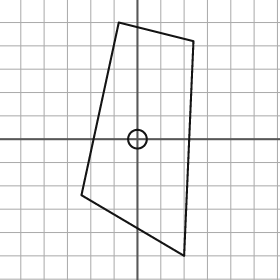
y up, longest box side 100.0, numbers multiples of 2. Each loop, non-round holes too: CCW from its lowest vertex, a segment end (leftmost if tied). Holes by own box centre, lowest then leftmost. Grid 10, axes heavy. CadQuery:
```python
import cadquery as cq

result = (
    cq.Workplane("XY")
    .moveTo(20.0, -50.0)
    .lineTo(24.0, 42.0)
    .lineTo(-8.0, 50.0)
    .lineTo(-24.0, -24.0)
    .close()
    .moveTo(0.0, 0.0)
    .circle(4.0)
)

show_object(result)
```